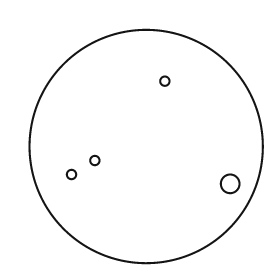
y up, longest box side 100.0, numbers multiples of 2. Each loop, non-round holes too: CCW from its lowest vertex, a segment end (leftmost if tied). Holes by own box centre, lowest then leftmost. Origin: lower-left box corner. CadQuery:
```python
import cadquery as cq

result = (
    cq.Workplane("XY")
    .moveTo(50.0, 50.0)
    .circle(50.0)
    .moveTo(86.0, 34.0)
    .circle(4.0)
    .moveTo(18.0, 38.0)
    .circle(2.0)
    .moveTo(28.0, 44.0)
    .circle(2.0)
    .moveTo(58.0, 78.0)
    .circle(2.0)
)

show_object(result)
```